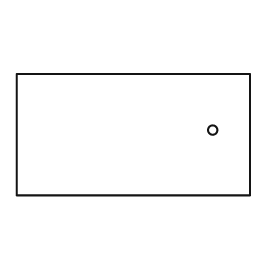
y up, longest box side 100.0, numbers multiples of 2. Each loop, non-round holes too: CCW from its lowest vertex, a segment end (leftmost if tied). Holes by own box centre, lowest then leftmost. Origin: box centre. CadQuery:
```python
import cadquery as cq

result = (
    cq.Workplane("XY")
    .moveTo(-50.0, -26.0)
    .lineTo(50.0, -26.0)
    .lineTo(50.0, 26.0)
    .lineTo(-50.0, 26.0)
    .close()
    .moveTo(34.0, 2.0)
    .circle(2.0)
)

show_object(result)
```